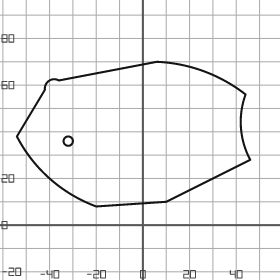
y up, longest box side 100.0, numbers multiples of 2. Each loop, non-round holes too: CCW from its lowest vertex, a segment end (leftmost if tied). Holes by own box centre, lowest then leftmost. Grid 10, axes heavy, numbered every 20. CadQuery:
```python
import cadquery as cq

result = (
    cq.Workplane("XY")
    .moveTo(-20.0, 8.0)
    .lineTo(10.0, 10.0)
    .lineTo(46.0, 28.0)
    .threePointArc((42.0, 42.0), (44.0, 56.0))
    .threePointArc((26.0, 66.0), (6.0, 70.0))
    .lineTo(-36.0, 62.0)
    .threePointArc((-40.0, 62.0), (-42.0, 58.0))
    .lineTo(-54.0, 38.0)
    .threePointArc((-40.0, 20.0), (-20.0, 8.0))
    .close()
    .moveTo(-32.0, 36.0)
    .circle(2.0)
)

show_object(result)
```